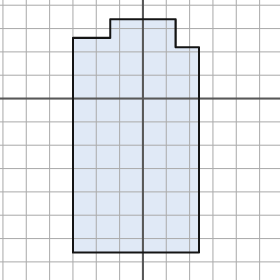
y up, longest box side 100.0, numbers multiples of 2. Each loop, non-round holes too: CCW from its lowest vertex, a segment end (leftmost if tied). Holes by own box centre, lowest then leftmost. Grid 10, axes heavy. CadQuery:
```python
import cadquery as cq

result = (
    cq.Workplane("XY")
    .moveTo(-30.0, -66.0)
    .lineTo(24.0, -66.0)
    .lineTo(24.0, 22.0)
    .lineTo(14.0, 22.0)
    .lineTo(14.0, 34.0)
    .lineTo(-14.0, 34.0)
    .lineTo(-14.0, 26.0)
    .lineTo(-30.0, 26.0)
    .close()
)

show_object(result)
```